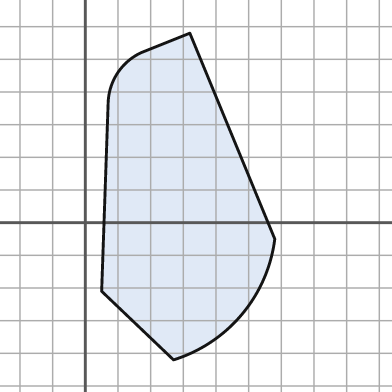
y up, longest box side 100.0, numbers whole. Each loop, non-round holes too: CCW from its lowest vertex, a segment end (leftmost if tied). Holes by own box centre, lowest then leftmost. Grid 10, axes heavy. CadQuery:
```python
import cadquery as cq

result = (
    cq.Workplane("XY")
    .moveTo(27.0, -42.0)
    .threePointArc((48.0, -28.0), (58.0, -5.0))
    .lineTo(32.0, 58.0)
    .lineTo(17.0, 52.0)
    .threePointArc((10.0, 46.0), (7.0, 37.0))
    .lineTo(5.0, -21.0)
    .close()
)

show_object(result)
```